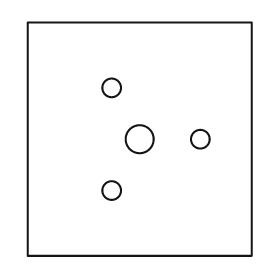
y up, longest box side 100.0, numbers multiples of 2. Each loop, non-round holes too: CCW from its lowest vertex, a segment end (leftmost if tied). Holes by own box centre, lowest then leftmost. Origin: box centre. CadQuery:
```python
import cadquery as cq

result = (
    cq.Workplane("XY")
    .moveTo(-48.0, -50.0)
    .lineTo(48.0, -50.0)
    .lineTo(48.0, 50.0)
    .lineTo(-48.0, 50.0)
    .close()
    .moveTo(-12.0, -22.0)
    .circle(4.0)
    .moveTo(0.0, 0.0)
    .circle(6.0)
    .moveTo(26.0, 0.0)
    .circle(4.0)
    .moveTo(-12.0, 22.0)
    .circle(4.0)
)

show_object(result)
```